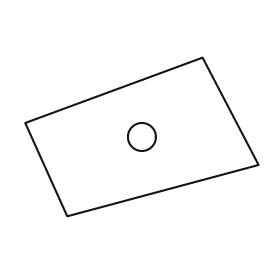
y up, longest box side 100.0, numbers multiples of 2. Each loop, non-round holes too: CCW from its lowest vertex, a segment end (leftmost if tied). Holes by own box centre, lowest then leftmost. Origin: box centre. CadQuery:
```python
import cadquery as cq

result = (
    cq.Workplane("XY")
    .moveTo(-32.0, -34.0)
    .lineTo(50.0, -12.0)
    .lineTo(26.0, 34.0)
    .lineTo(-50.0, 6.0)
    .close()
    .moveTo(0.0, 0.0)
    .circle(6.0)
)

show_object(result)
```